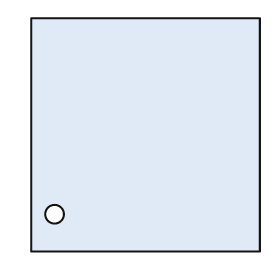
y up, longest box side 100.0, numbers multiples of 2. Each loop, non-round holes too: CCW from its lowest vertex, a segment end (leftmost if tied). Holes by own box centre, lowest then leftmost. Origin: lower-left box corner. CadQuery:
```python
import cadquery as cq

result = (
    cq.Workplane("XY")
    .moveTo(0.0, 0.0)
    .lineTo(98.0, 0.0)
    .lineTo(98.0, 100.0)
    .lineTo(0.0, 100.0)
    .close()
    .moveTo(10.0, 16.0)
    .circle(4.0)
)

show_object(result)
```